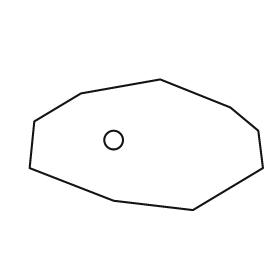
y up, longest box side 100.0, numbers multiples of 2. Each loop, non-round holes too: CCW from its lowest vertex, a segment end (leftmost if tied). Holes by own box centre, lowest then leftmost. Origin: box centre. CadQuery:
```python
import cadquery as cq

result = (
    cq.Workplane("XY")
    .moveTo(20.0, -28.0)
    .lineTo(50.0, -10.0)
    .lineTo(48.0, 6.0)
    .lineTo(36.0, 16.0)
    .lineTo(6.0, 28.0)
    .lineTo(-28.0, 22.0)
    .lineTo(-48.0, 10.0)
    .lineTo(-50.0, -10.0)
    .lineTo(-14.0, -24.0)
    .close()
    .moveTo(-14.0, 2.0)
    .circle(4.0)
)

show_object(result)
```